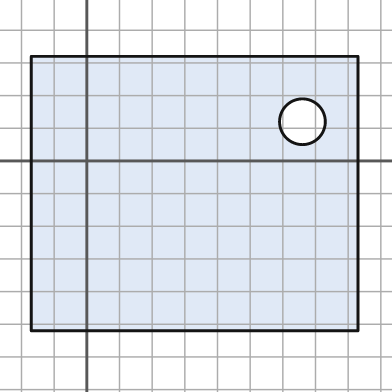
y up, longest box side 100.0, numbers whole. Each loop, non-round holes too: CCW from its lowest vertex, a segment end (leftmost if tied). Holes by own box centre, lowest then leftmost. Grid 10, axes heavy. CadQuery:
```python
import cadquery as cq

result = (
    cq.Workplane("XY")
    .moveTo(-17.0, -52.0)
    .lineTo(83.0, -52.0)
    .lineTo(83.0, 32.0)
    .lineTo(-17.0, 32.0)
    .close()
    .moveTo(66.0, 12.0)
    .circle(7.0)
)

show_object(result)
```